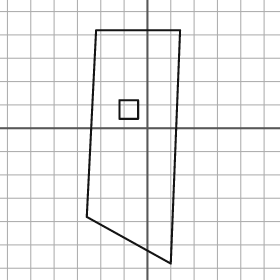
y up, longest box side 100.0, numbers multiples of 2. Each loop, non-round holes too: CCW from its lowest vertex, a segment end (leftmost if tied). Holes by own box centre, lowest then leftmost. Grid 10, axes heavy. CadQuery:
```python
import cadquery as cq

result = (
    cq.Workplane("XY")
    .moveTo(10.0, -58.0)
    .lineTo(14.0, 42.0)
    .lineTo(-22.0, 42.0)
    .lineTo(-26.0, -38.0)
    .close()
    .moveTo(-12.0, 4.0)
    .lineTo(-4.0, 4.0)
    .lineTo(-4.0, 12.0)
    .lineTo(-12.0, 12.0)
    .close()
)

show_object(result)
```